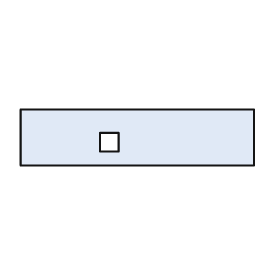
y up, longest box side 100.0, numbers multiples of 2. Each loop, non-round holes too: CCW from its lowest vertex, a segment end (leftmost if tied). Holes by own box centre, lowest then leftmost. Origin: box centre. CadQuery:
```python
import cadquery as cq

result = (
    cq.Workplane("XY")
    .moveTo(-50.0, -12.0)
    .lineTo(50.0, -12.0)
    .lineTo(50.0, 12.0)
    .lineTo(-50.0, 12.0)
    .close()
    .moveTo(-16.0, -6.0)
    .lineTo(-8.0, -6.0)
    .lineTo(-8.0, 2.0)
    .lineTo(-16.0, 2.0)
    .close()
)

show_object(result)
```